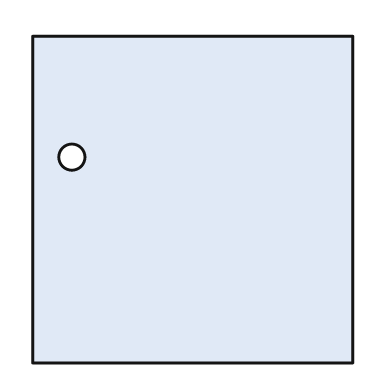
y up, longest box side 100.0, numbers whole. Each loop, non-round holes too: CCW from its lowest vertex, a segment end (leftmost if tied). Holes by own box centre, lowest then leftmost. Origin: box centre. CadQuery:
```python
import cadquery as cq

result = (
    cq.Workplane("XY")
    .moveTo(-49.0, -50.0)
    .lineTo(49.0, -50.0)
    .lineTo(49.0, 50.0)
    .lineTo(-49.0, 50.0)
    .close()
    .moveTo(-37.0, 13.0)
    .circle(4.0)
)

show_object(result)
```